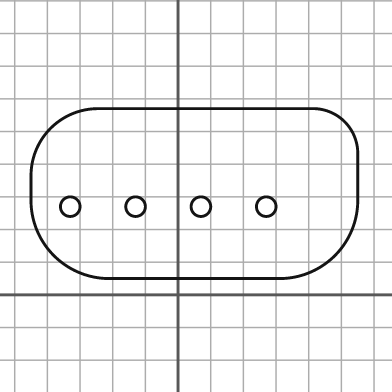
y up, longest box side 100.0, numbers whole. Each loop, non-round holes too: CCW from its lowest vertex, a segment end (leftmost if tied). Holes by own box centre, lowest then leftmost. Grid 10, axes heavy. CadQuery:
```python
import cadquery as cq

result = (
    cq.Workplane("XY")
    .moveTo(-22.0, 5.0)
    .lineTo(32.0, 5.0)
    .threePointArc((48.0, 12.0), (55.0, 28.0))
    .lineTo(55.0, 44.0)
    .threePointArc((51.0, 53.0), (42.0, 57.0))
    .lineTo(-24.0, 57.0)
    .threePointArc((-39.0, 51.0), (-45.0, 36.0))
    .lineTo(-45.0, 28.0)
    .threePointArc((-38.0, 12.0), (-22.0, 5.0))
    .close()
    .moveTo(-33.0, 27.0)
    .circle(3.0)
    .moveTo(-13.0, 27.0)
    .circle(3.0)
    .moveTo(7.0, 27.0)
    .circle(3.0)
    .moveTo(27.0, 27.0)
    .circle(3.0)
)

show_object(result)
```